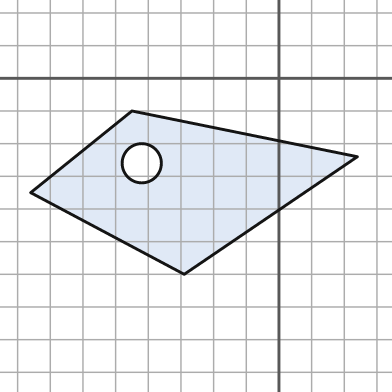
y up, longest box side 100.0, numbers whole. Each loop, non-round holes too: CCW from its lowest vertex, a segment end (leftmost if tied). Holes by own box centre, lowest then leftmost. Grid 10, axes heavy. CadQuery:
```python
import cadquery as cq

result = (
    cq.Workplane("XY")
    .moveTo(-29.0, -60.0)
    .lineTo(24.0, -24.0)
    .lineTo(-45.0, -10.0)
    .lineTo(-76.0, -35.0)
    .close()
    .moveTo(-42.0, -26.0)
    .circle(6.0)
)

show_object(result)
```